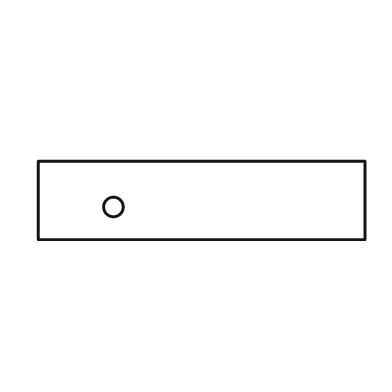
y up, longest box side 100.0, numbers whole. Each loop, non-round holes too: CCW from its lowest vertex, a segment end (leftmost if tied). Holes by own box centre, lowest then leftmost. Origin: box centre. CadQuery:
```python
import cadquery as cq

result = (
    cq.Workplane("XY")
    .moveTo(-50.0, -12.0)
    .lineTo(50.0, -12.0)
    .lineTo(50.0, 12.0)
    .lineTo(-50.0, 12.0)
    .close()
    .moveTo(-27.0, -2.0)
    .circle(3.0)
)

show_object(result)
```